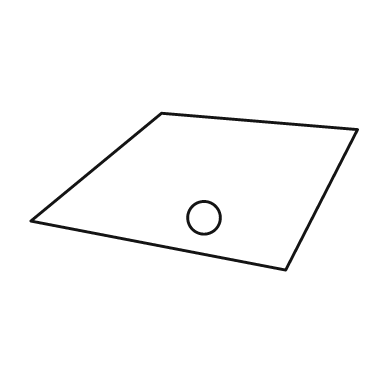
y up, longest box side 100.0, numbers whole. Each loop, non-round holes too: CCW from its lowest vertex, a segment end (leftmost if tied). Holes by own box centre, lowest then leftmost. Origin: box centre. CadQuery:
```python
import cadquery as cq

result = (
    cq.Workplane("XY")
    .moveTo(28.0, -24.0)
    .lineTo(50.0, 19.0)
    .lineTo(-10.0, 24.0)
    .lineTo(-50.0, -9.0)
    .close()
    .moveTo(3.0, -8.0)
    .circle(5.0)
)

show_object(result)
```